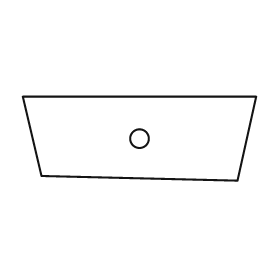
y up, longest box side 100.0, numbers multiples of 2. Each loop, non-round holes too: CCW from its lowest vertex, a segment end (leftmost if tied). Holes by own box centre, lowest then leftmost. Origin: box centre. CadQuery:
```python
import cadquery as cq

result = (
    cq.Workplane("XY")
    .moveTo(42.0, -18.0)
    .lineTo(50.0, 18.0)
    .lineTo(-50.0, 18.0)
    .lineTo(-42.0, -16.0)
    .close()
    .moveTo(0.0, 0.0)
    .circle(4.0)
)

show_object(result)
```